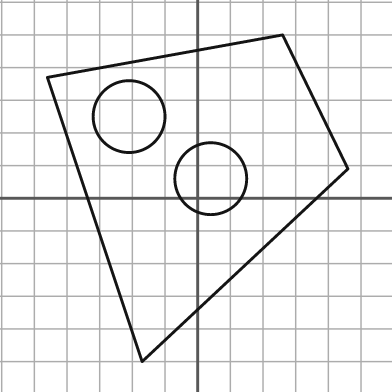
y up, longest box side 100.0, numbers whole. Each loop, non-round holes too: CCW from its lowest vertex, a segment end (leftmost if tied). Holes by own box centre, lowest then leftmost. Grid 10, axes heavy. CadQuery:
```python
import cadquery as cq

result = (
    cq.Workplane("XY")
    .moveTo(-17.0, -50.0)
    .lineTo(46.0, 9.0)
    .lineTo(26.0, 50.0)
    .lineTo(-46.0, 37.0)
    .close()
    .moveTo(4.0, 6.0)
    .circle(11.0)
    .moveTo(-21.0, 25.0)
    .circle(11.0)
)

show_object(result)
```